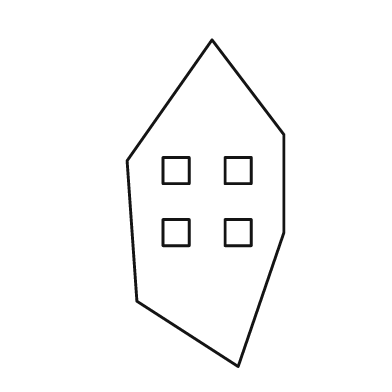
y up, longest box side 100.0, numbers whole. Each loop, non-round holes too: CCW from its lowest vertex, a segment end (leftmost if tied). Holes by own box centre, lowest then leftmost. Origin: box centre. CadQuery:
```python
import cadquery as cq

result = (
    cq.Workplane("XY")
    .moveTo(10.0, -50.0)
    .lineTo(24.0, -9.0)
    .lineTo(24.0, 21.0)
    .lineTo(2.0, 50.0)
    .lineTo(-24.0, 13.0)
    .lineTo(-21.0, -30.0)
    .close()
    .moveTo(-13.0, -13.0)
    .lineTo(-5.0, -13.0)
    .lineTo(-5.0, -5.0)
    .lineTo(-13.0, -5.0)
    .close()
    .moveTo(6.0, -13.0)
    .lineTo(14.0, -13.0)
    .lineTo(14.0, -5.0)
    .lineTo(6.0, -5.0)
    .close()
    .moveTo(-13.0, 6.0)
    .lineTo(-5.0, 6.0)
    .lineTo(-5.0, 14.0)
    .lineTo(-13.0, 14.0)
    .close()
    .moveTo(6.0, 6.0)
    .lineTo(14.0, 6.0)
    .lineTo(14.0, 14.0)
    .lineTo(6.0, 14.0)
    .close()
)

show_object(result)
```